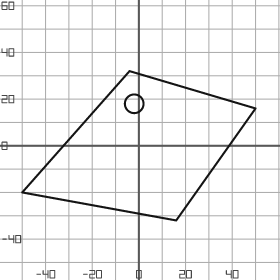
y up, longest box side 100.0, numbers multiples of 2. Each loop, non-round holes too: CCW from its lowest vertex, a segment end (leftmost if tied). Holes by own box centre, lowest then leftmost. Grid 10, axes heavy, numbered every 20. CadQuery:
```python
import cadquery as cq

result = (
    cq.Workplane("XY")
    .moveTo(16.0, -32.0)
    .lineTo(50.0, 16.0)
    .lineTo(-4.0, 32.0)
    .lineTo(-50.0, -20.0)
    .close()
    .moveTo(-2.0, 18.0)
    .circle(4.0)
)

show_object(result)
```